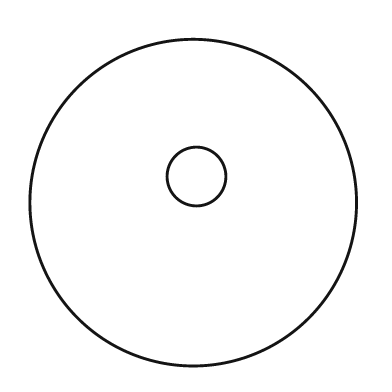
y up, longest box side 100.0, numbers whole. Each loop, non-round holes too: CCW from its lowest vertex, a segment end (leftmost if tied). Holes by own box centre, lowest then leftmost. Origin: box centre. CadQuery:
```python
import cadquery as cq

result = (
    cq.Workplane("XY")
    .moveTo(0.0, 0.0)
    .circle(50.0)
    .moveTo(1.0, 8.0)
    .circle(9.0)
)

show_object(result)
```